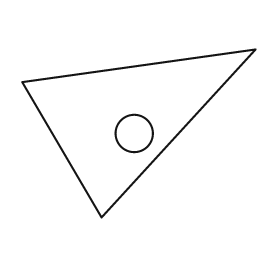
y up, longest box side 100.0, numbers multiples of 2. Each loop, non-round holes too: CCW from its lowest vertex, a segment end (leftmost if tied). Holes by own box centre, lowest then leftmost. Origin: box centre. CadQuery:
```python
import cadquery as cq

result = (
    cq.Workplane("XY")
    .moveTo(-16.0, -36.0)
    .lineTo(50.0, 36.0)
    .lineTo(-50.0, 22.0)
    .close()
    .moveTo(-2.0, 0.0)
    .circle(8.0)
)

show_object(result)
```